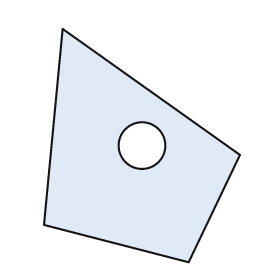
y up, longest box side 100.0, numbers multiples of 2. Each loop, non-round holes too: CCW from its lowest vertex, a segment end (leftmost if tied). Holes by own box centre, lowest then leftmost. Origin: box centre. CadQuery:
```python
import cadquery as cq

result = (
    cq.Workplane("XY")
    .moveTo(20.0, -50.0)
    .lineTo(42.0, -4.0)
    .lineTo(-34.0, 50.0)
    .lineTo(-42.0, -34.0)
    .close()
    .moveTo(0.0, 0.0)
    .circle(10.0)
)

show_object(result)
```